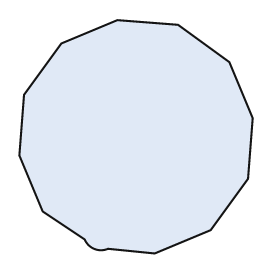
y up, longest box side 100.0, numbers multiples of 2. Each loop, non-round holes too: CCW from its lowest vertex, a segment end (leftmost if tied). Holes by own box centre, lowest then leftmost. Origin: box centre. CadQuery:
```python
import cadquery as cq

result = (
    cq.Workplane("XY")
    .moveTo(8.0, -50.0)
    .lineTo(32.0, -40.0)
    .lineTo(48.0, -18.0)
    .lineTo(50.0, 8.0)
    .lineTo(40.0, 32.0)
    .lineTo(18.0, 48.0)
    .lineTo(-8.0, 50.0)
    .lineTo(-32.0, 40.0)
    .lineTo(-48.0, 18.0)
    .lineTo(-50.0, -8.0)
    .lineTo(-40.0, -32.0)
    .lineTo(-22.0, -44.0)
    .threePointArc((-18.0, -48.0), (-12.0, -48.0))
    .close()
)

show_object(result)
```